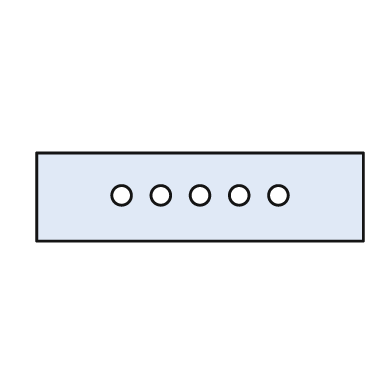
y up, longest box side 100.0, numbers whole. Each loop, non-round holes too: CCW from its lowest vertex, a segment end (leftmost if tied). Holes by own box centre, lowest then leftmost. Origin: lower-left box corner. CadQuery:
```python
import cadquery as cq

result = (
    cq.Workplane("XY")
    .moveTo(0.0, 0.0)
    .lineTo(100.0, 0.0)
    .lineTo(100.0, 27.0)
    .lineTo(0.0, 27.0)
    .close()
    .moveTo(26.0, 14.0)
    .circle(3.0)
    .moveTo(38.0, 14.0)
    .circle(3.0)
    .moveTo(50.0, 14.0)
    .circle(3.0)
    .moveTo(62.0, 14.0)
    .circle(3.0)
    .moveTo(74.0, 14.0)
    .circle(3.0)
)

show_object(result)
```